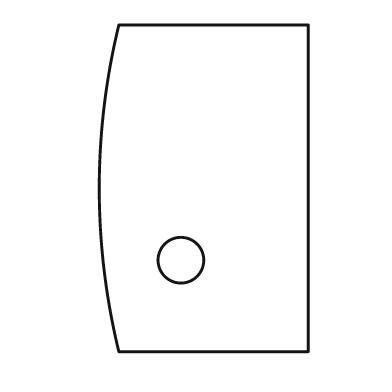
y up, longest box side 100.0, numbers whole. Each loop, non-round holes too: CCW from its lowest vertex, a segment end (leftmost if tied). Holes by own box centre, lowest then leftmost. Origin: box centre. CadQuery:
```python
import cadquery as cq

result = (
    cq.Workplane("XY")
    .moveTo(-26.0, -50.0)
    .lineTo(32.0, -50.0)
    .lineTo(32.0, 50.0)
    .lineTo(-26.0, 50.0)
    .threePointArc((-32.0, 0.0), (-26.0, -50.0))
    .close()
    .moveTo(-7.0, -22.0)
    .circle(7.0)
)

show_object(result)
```